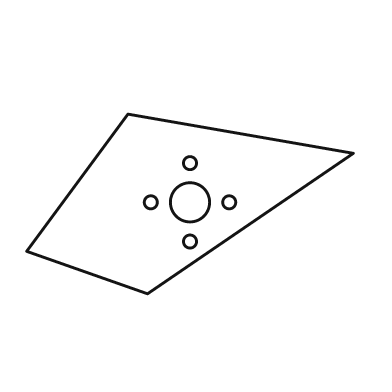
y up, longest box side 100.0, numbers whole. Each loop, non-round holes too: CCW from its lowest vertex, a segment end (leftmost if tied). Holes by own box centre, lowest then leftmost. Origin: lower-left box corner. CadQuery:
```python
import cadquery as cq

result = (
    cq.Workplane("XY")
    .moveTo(37.0, 0.0)
    .lineTo(100.0, 43.0)
    .lineTo(31.0, 55.0)
    .lineTo(0.0, 13.0)
    .close()
    .moveTo(50.0, 16.0)
    .circle(2.0)
    .moveTo(38.0, 28.0)
    .circle(2.0)
    .moveTo(50.0, 28.0)
    .circle(6.0)
    .moveTo(62.0, 28.0)
    .circle(2.0)
    .moveTo(50.0, 40.0)
    .circle(2.0)
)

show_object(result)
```